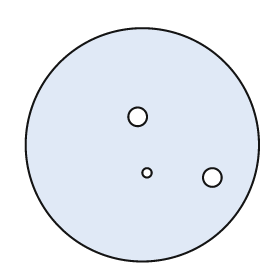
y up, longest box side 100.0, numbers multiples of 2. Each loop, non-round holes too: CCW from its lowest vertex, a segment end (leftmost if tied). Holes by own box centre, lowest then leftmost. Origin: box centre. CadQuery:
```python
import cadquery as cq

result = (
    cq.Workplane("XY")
    .moveTo(0.0, 0.0)
    .circle(50.0)
    .moveTo(30.0, -14.0)
    .circle(4.0)
    .moveTo(2.0, -12.0)
    .circle(2.0)
    .moveTo(-2.0, 12.0)
    .circle(4.0)
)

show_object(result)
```